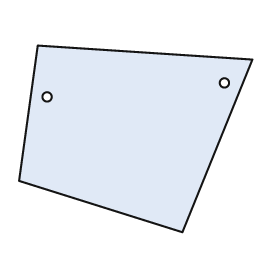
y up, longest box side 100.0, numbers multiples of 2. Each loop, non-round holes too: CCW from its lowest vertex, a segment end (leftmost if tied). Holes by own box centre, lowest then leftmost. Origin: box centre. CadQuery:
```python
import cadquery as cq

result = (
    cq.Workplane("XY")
    .moveTo(20.0, -40.0)
    .lineTo(50.0, 34.0)
    .lineTo(-42.0, 40.0)
    .lineTo(-50.0, -18.0)
    .close()
    .moveTo(-38.0, 18.0)
    .circle(2.0)
    .moveTo(38.0, 24.0)
    .circle(2.0)
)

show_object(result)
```